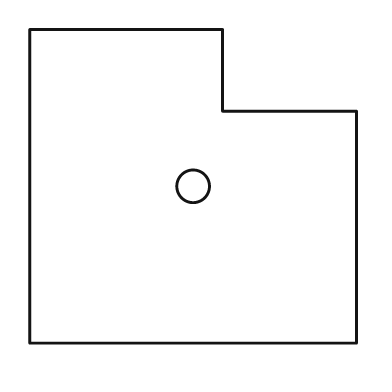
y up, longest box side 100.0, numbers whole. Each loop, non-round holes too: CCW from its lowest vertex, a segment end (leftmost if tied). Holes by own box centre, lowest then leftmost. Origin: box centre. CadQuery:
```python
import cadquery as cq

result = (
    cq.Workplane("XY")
    .moveTo(-50.0, -48.0)
    .lineTo(50.0, -48.0)
    .lineTo(50.0, 23.0)
    .lineTo(9.0, 23.0)
    .lineTo(9.0, 48.0)
    .lineTo(-50.0, 48.0)
    .close()
    .moveTo(0.0, 0.0)
    .circle(5.0)
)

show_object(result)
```